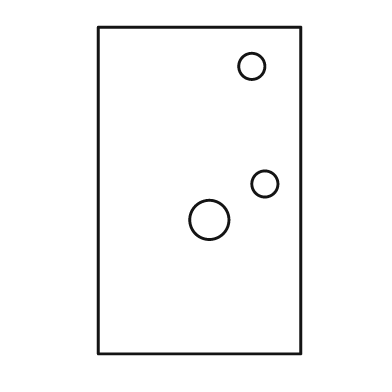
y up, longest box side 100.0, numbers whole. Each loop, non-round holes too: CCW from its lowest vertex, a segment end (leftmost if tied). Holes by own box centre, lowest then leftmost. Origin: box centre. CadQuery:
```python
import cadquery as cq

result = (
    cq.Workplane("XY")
    .moveTo(-31.0, -50.0)
    .lineTo(31.0, -50.0)
    .lineTo(31.0, 50.0)
    .lineTo(-31.0, 50.0)
    .close()
    .moveTo(3.0, -9.0)
    .circle(6.0)
    .moveTo(20.0, 2.0)
    .circle(4.0)
    .moveTo(16.0, 38.0)
    .circle(4.0)
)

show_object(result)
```